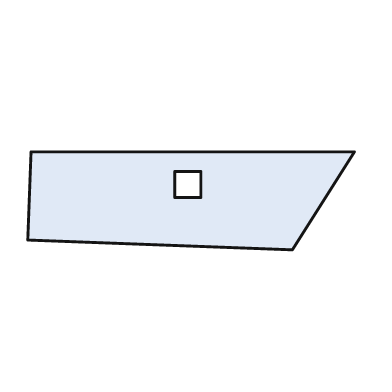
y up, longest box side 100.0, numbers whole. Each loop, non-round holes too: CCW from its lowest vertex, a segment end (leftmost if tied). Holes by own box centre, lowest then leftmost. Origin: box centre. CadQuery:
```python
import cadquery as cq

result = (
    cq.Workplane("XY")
    .moveTo(31.0, -15.0)
    .lineTo(50.0, 15.0)
    .lineTo(-49.0, 15.0)
    .lineTo(-50.0, -12.0)
    .close()
    .moveTo(-5.0, 1.0)
    .lineTo(3.0, 1.0)
    .lineTo(3.0, 9.0)
    .lineTo(-5.0, 9.0)
    .close()
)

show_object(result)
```